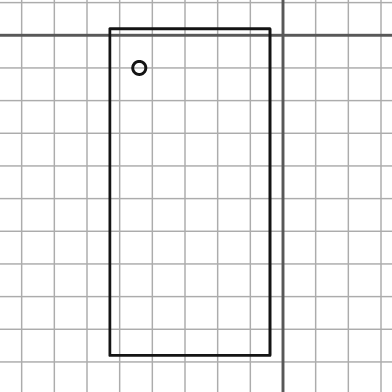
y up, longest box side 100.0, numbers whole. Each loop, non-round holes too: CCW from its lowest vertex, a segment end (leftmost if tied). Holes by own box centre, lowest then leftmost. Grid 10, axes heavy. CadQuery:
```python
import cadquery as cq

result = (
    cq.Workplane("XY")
    .moveTo(-53.0, -98.0)
    .lineTo(-4.0, -98.0)
    .lineTo(-4.0, 2.0)
    .lineTo(-53.0, 2.0)
    .close()
    .moveTo(-44.0, -10.0)
    .circle(2.0)
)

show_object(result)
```